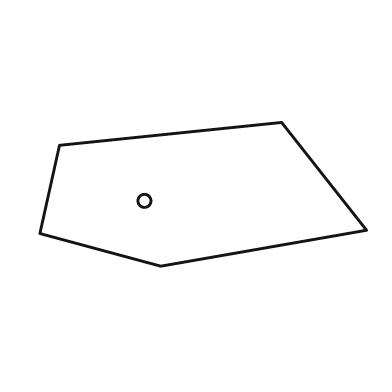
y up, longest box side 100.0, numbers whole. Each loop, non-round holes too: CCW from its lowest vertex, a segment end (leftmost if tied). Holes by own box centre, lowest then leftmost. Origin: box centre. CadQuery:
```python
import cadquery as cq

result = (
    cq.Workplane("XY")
    .moveTo(-13.0, -22.0)
    .lineTo(50.0, -11.0)
    .lineTo(24.0, 22.0)
    .lineTo(-44.0, 15.0)
    .lineTo(-50.0, -12.0)
    .close()
    .moveTo(-18.0, -2.0)
    .circle(2.0)
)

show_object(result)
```